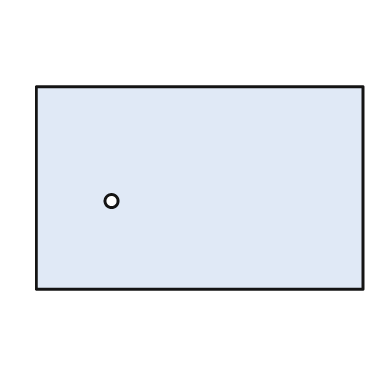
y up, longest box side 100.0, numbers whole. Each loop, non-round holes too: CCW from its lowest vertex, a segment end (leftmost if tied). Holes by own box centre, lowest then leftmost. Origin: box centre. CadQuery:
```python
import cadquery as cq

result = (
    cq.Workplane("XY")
    .moveTo(-50.0, -31.0)
    .lineTo(50.0, -31.0)
    .lineTo(50.0, 31.0)
    .lineTo(-50.0, 31.0)
    .close()
    .moveTo(-27.0, -4.0)
    .circle(2.0)
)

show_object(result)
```